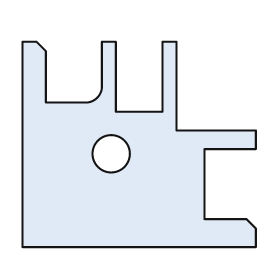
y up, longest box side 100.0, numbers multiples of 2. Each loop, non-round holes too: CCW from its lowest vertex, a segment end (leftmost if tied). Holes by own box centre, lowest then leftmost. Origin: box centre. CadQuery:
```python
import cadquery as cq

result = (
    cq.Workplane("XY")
    .moveTo(-50.0, -44.0)
    .lineTo(50.0, -44.0)
    .lineTo(50.0, -36.0)
    .lineTo(46.0, -32.0)
    .lineTo(28.0, -32.0)
    .lineTo(28.0, -2.0)
    .lineTo(50.0, -2.0)
    .lineTo(50.0, 6.0)
    .lineTo(16.0, 6.0)
    .lineTo(16.0, 44.0)
    .lineTo(10.0, 44.0)
    .lineTo(10.0, 14.0)
    .lineTo(-10.0, 14.0)
    .lineTo(-10.0, 44.0)
    .lineTo(-16.0, 44.0)
    .lineTo(-16.0, 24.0)
    .threePointArc((-18.0, 20.0), (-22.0, 18.0))
    .lineTo(-40.0, 18.0)
    .lineTo(-40.0, 40.0)
    .lineTo(-44.0, 44.0)
    .lineTo(-50.0, 44.0)
    .close()
    .moveTo(-12.0, -4.0)
    .circle(8.0)
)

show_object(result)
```